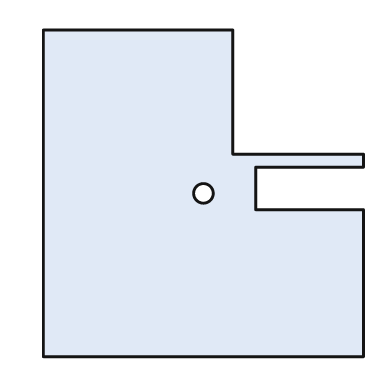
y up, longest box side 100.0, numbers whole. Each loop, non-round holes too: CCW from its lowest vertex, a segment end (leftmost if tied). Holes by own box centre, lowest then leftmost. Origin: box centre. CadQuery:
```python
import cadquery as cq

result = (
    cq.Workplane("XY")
    .moveTo(-49.0, -50.0)
    .lineTo(49.0, -50.0)
    .lineTo(49.0, -5.0)
    .lineTo(16.0, -5.0)
    .lineTo(16.0, 8.0)
    .lineTo(49.0, 8.0)
    .lineTo(49.0, 12.0)
    .lineTo(9.0, 12.0)
    .lineTo(9.0, 50.0)
    .lineTo(-49.0, 50.0)
    .close()
    .moveTo(0.0, 0.0)
    .circle(3.0)
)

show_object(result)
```